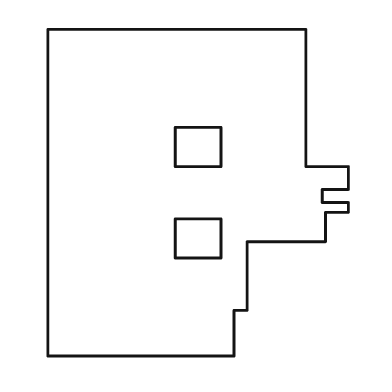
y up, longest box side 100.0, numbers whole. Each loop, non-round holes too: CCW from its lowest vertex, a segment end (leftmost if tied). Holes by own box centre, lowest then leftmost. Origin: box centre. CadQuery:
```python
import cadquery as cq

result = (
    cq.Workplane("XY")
    .moveTo(-46.0, -50.0)
    .lineTo(11.0, -50.0)
    .lineTo(11.0, -36.0)
    .lineTo(15.0, -36.0)
    .lineTo(15.0, -15.0)
    .lineTo(39.0, -15.0)
    .lineTo(39.0, -6.0)
    .lineTo(46.0, -6.0)
    .lineTo(46.0, -3.0)
    .lineTo(38.0, -3.0)
    .lineTo(38.0, 1.0)
    .lineTo(46.0, 1.0)
    .lineTo(46.0, 8.0)
    .lineTo(33.0, 8.0)
    .lineTo(33.0, 50.0)
    .lineTo(-46.0, 50.0)
    .close()
    .moveTo(-7.0, -20.0)
    .lineTo(7.0, -20.0)
    .lineTo(7.0, -8.0)
    .lineTo(-7.0, -8.0)
    .close()
    .moveTo(-7.0, 8.0)
    .lineTo(7.0, 8.0)
    .lineTo(7.0, 20.0)
    .lineTo(-7.0, 20.0)
    .close()
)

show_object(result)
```